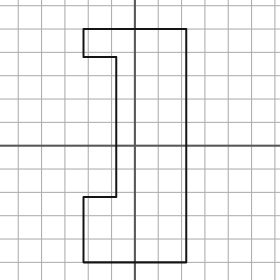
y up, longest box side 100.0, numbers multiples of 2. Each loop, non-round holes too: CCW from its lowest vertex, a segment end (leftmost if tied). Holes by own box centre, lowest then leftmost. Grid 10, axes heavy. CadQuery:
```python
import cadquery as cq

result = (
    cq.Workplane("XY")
    .moveTo(-22.0, -50.0)
    .lineTo(22.0, -50.0)
    .lineTo(22.0, 50.0)
    .lineTo(-22.0, 50.0)
    .lineTo(-22.0, 38.0)
    .lineTo(-8.0, 38.0)
    .lineTo(-8.0, -22.0)
    .lineTo(-22.0, -22.0)
    .close()
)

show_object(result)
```